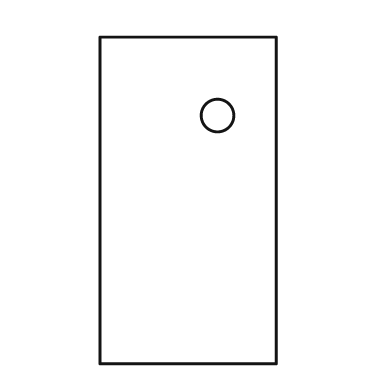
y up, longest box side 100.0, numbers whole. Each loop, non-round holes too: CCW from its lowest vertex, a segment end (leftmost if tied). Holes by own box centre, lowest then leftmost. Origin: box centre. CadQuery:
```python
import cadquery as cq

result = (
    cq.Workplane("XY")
    .moveTo(-27.0, -50.0)
    .lineTo(27.0, -50.0)
    .lineTo(27.0, 50.0)
    .lineTo(-27.0, 50.0)
    .close()
    .moveTo(9.0, 26.0)
    .circle(5.0)
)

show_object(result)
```